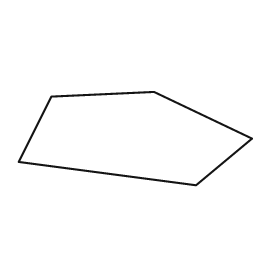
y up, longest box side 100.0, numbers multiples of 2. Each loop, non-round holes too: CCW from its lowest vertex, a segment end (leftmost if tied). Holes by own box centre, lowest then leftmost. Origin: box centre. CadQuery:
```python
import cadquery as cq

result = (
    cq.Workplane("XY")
    .moveTo(26.0, -20.0)
    .lineTo(50.0, 0.0)
    .lineTo(8.0, 20.0)
    .lineTo(-36.0, 18.0)
    .lineTo(-50.0, -10.0)
    .close()
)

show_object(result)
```